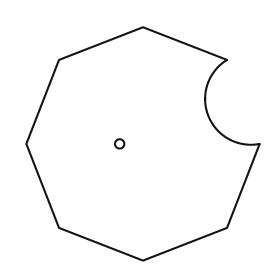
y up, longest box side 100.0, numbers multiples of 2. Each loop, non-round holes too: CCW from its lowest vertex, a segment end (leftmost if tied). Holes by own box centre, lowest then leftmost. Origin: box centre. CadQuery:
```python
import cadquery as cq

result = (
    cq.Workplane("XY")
    .moveTo(0.0, -50.0)
    .lineTo(36.0, -36.0)
    .lineTo(50.0, 0.0)
    .threePointArc((28.0, 12.0), (36.0, 36.0))
    .lineTo(0.0, 50.0)
    .lineTo(-36.0, 36.0)
    .lineTo(-50.0, 0.0)
    .lineTo(-36.0, -36.0)
    .close()
    .moveTo(-10.0, 0.0)
    .circle(2.0)
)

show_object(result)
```